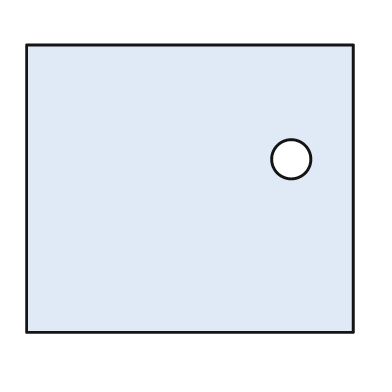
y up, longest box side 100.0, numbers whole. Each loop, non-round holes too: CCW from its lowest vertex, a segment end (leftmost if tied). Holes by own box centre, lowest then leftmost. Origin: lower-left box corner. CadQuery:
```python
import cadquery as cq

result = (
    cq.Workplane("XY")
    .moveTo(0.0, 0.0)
    .lineTo(100.0, 0.0)
    .lineTo(100.0, 88.0)
    .lineTo(0.0, 88.0)
    .close()
    .moveTo(81.0, 53.0)
    .circle(6.0)
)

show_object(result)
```